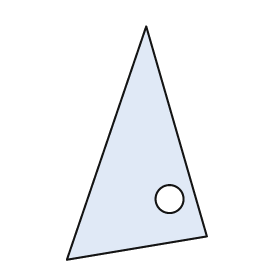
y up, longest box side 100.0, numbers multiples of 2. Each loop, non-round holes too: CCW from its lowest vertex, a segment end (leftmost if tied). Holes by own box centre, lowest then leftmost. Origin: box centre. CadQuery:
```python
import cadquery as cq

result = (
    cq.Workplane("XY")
    .moveTo(-30.0, -50.0)
    .lineTo(30.0, -40.0)
    .lineTo(4.0, 50.0)
    .close()
    .moveTo(14.0, -24.0)
    .circle(6.0)
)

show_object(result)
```